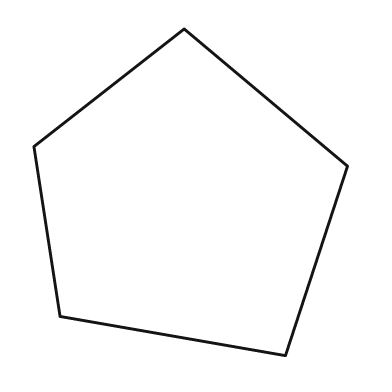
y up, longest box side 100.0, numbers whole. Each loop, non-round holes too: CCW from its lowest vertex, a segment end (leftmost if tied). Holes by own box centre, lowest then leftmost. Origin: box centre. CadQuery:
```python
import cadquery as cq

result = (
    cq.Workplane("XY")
    .moveTo(29.0, -50.0)
    .lineTo(48.0, 8.0)
    .lineTo(-2.0, 50.0)
    .lineTo(-48.0, 14.0)
    .lineTo(-40.0, -38.0)
    .close()
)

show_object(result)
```